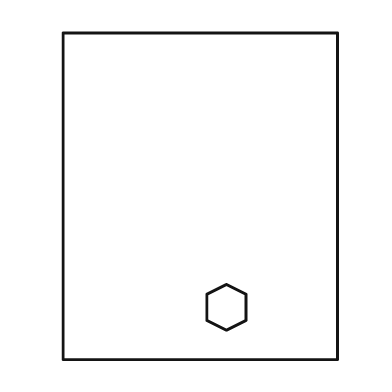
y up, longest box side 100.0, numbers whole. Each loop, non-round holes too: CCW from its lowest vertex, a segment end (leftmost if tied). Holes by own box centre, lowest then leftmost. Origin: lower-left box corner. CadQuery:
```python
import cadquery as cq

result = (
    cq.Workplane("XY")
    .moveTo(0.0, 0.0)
    .lineTo(84.0, 0.0)
    .lineTo(84.0, 100.0)
    .lineTo(0.0, 100.0)
    .close()
    .moveTo(50.0, 9.0)
    .lineTo(56.0, 12.0)
    .lineTo(56.0, 20.0)
    .lineTo(50.0, 23.0)
    .lineTo(44.0, 20.0)
    .lineTo(44.0, 12.0)
    .close()
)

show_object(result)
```